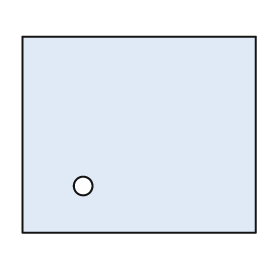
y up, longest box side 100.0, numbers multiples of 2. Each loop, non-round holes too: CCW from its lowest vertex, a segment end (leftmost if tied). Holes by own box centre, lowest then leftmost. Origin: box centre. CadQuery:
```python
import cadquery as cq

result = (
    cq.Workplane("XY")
    .moveTo(-50.0, -42.0)
    .lineTo(50.0, -42.0)
    .lineTo(50.0, 42.0)
    .lineTo(-50.0, 42.0)
    .close()
    .moveTo(-24.0, -22.0)
    .circle(4.0)
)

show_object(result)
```